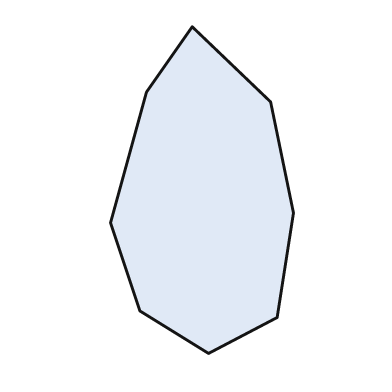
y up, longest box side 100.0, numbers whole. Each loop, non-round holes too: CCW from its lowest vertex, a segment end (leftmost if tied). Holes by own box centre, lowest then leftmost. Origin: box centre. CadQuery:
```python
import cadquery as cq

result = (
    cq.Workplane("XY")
    .moveTo(2.0, -50.0)
    .lineTo(23.0, -39.0)
    .lineTo(28.0, -7.0)
    .lineTo(21.0, 27.0)
    .lineTo(-3.0, 50.0)
    .lineTo(-17.0, 30.0)
    .lineTo(-28.0, -10.0)
    .lineTo(-19.0, -37.0)
    .close()
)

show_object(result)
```